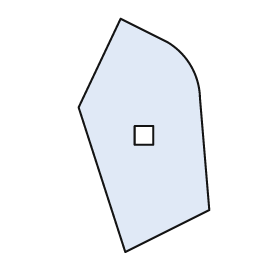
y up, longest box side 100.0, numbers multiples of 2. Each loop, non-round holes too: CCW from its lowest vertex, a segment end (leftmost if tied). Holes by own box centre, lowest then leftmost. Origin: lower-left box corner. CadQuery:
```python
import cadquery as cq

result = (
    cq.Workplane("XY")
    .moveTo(20.0, 0.0)
    .lineTo(56.0, 18.0)
    .lineTo(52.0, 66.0)
    .threePointArc((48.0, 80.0), (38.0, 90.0))
    .lineTo(18.0, 100.0)
    .lineTo(0.0, 62.0)
    .close()
    .moveTo(24.0, 46.0)
    .lineTo(32.0, 46.0)
    .lineTo(32.0, 54.0)
    .lineTo(24.0, 54.0)
    .close()
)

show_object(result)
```